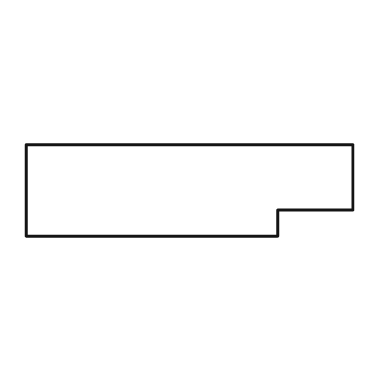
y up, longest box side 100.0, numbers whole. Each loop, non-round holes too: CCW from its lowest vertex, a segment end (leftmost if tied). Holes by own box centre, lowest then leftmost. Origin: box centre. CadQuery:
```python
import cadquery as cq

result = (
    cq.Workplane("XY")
    .moveTo(-50.0, -14.0)
    .lineTo(27.0, -14.0)
    .lineTo(27.0, -6.0)
    .lineTo(50.0, -6.0)
    .lineTo(50.0, 14.0)
    .lineTo(-50.0, 14.0)
    .close()
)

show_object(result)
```